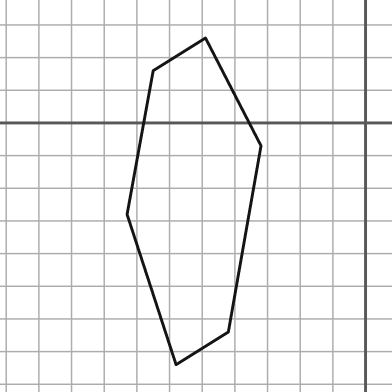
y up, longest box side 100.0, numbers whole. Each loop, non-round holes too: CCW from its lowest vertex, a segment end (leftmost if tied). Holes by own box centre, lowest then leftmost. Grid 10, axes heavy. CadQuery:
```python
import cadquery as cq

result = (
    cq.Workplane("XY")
    .moveTo(-58.0, -74.0)
    .lineTo(-42.0, -64.0)
    .lineTo(-32.0, -7.0)
    .lineTo(-49.0, 26.0)
    .lineTo(-65.0, 16.0)
    .lineTo(-73.0, -28.0)
    .close()
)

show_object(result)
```